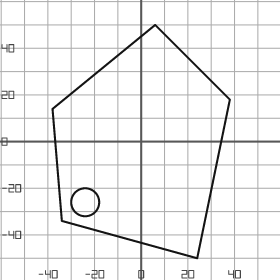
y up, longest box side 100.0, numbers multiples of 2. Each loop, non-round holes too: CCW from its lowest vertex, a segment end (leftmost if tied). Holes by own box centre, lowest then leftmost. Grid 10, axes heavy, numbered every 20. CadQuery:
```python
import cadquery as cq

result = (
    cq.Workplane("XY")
    .moveTo(24.0, -50.0)
    .lineTo(38.0, 18.0)
    .lineTo(6.0, 50.0)
    .lineTo(-38.0, 14.0)
    .lineTo(-34.0, -34.0)
    .close()
    .moveTo(-24.0, -26.0)
    .circle(6.0)
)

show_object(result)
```